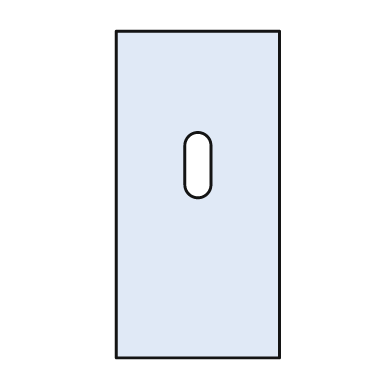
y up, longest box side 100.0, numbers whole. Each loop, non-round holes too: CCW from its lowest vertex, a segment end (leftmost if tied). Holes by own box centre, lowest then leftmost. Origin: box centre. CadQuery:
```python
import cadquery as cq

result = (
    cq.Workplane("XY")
    .moveTo(-25.0, -50.0)
    .lineTo(25.0, -50.0)
    .lineTo(25.0, 50.0)
    .lineTo(-25.0, 50.0)
    .close()
    .moveTo(-4.0, 3.0)
    .threePointArc((0.0, -1.0), (4.0, 3.0))
    .lineTo(4.0, 15.0)
    .threePointArc((0.0, 19.0), (-4.0, 15.0))
    .close()
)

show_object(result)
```